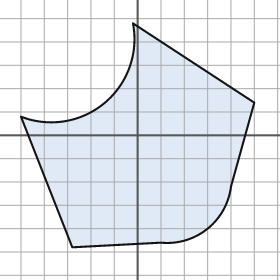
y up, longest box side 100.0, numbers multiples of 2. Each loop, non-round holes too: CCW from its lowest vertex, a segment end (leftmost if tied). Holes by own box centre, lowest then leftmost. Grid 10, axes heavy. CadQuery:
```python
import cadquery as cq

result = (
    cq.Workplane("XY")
    .moveTo(-28.0, -48.0)
    .lineTo(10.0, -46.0)
    .threePointArc((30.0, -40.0), (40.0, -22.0))
    .lineTo(50.0, 14.0)
    .lineTo(-2.0, 48.0)
    .threePointArc((-14.0, 14.0), (-50.0, 8.0))
    .close()
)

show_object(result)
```